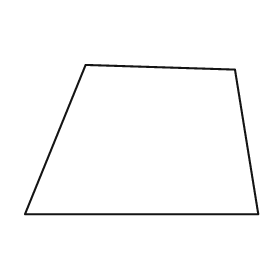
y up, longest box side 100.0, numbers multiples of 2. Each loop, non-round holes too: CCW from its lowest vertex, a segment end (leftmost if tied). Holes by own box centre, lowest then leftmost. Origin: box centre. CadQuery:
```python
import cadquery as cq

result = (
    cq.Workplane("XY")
    .moveTo(-50.0, -32.0)
    .lineTo(50.0, -32.0)
    .lineTo(40.0, 30.0)
    .lineTo(-24.0, 32.0)
    .close()
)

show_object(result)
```